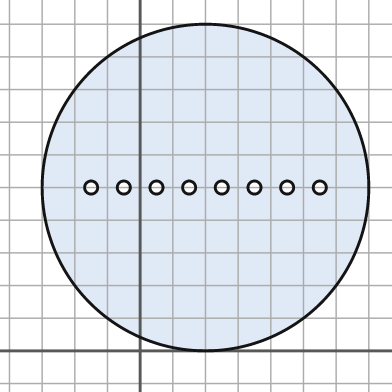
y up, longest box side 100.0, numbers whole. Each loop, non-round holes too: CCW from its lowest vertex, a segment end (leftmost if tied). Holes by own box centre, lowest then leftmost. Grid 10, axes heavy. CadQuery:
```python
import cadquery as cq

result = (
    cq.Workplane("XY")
    .moveTo(20.0, 50.0)
    .circle(50.0)
    .moveTo(-15.0, 50.0)
    .circle(2.0)
    .moveTo(-5.0, 50.0)
    .circle(2.0)
    .moveTo(5.0, 50.0)
    .circle(2.0)
    .moveTo(15.0, 50.0)
    .circle(2.0)
    .moveTo(25.0, 50.0)
    .circle(2.0)
    .moveTo(35.0, 50.0)
    .circle(2.0)
    .moveTo(45.0, 50.0)
    .circle(2.0)
    .moveTo(55.0, 50.0)
    .circle(2.0)
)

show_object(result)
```